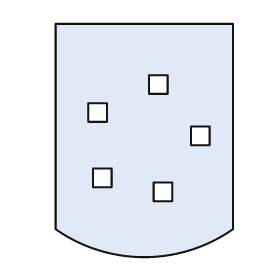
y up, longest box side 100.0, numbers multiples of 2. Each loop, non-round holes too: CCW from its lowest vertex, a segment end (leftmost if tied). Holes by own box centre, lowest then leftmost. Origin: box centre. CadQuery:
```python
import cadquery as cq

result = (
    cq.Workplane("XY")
    .moveTo(-38.0, -38.0)
    .threePointArc((0.0, -50.0), (38.0, -38.0))
    .lineTo(38.0, 50.0)
    .lineTo(-38.0, 50.0)
    .close()
    .moveTo(4.0, -26.0)
    .lineTo(12.0, -26.0)
    .lineTo(12.0, -18.0)
    .lineTo(4.0, -18.0)
    .close()
    .moveTo(-22.0, -20.0)
    .lineTo(-14.0, -20.0)
    .lineTo(-14.0, -12.0)
    .lineTo(-22.0, -12.0)
    .close()
    .moveTo(20.0, -2.0)
    .lineTo(28.0, -2.0)
    .lineTo(28.0, 6.0)
    .lineTo(20.0, 6.0)
    .close()
    .moveTo(-24.0, 8.0)
    .lineTo(-16.0, 8.0)
    .lineTo(-16.0, 16.0)
    .lineTo(-24.0, 16.0)
    .close()
    .moveTo(2.0, 20.0)
    .lineTo(10.0, 20.0)
    .lineTo(10.0, 28.0)
    .lineTo(2.0, 28.0)
    .close()
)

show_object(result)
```